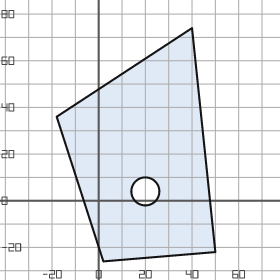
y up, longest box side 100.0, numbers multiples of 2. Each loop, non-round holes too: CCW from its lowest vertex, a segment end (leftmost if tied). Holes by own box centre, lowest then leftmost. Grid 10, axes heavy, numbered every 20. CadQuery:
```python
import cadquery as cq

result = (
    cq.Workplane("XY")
    .moveTo(2.0, -26.0)
    .lineTo(50.0, -22.0)
    .lineTo(40.0, 74.0)
    .lineTo(-18.0, 36.0)
    .close()
    .moveTo(20.0, 4.0)
    .circle(6.0)
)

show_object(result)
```